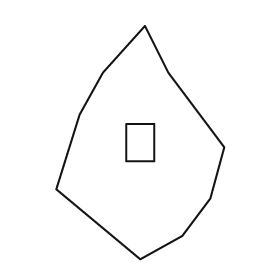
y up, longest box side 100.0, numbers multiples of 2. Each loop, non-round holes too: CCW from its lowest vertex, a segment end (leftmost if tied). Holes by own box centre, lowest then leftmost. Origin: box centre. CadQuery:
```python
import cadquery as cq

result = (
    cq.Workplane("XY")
    .moveTo(0.0, -50.0)
    .lineTo(18.0, -40.0)
    .lineTo(30.0, -24.0)
    .lineTo(36.0, -2.0)
    .lineTo(12.0, 30.0)
    .lineTo(2.0, 50.0)
    .lineTo(-16.0, 30.0)
    .lineTo(-26.0, 12.0)
    .lineTo(-36.0, -20.0)
    .close()
    .moveTo(-6.0, -8.0)
    .lineTo(6.0, -8.0)
    .lineTo(6.0, 8.0)
    .lineTo(-6.0, 8.0)
    .close()
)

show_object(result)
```